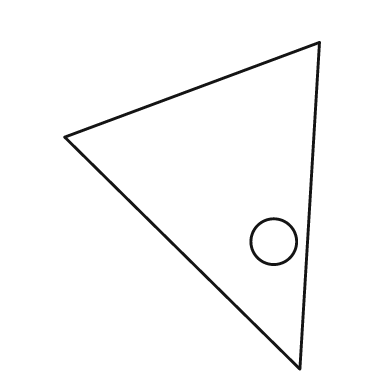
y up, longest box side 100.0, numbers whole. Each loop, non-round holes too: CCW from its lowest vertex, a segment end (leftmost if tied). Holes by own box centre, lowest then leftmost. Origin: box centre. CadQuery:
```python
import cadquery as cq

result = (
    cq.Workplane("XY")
    .moveTo(33.0, -50.0)
    .lineTo(39.0, 50.0)
    .lineTo(-39.0, 21.0)
    .close()
    .moveTo(25.0, -11.0)
    .circle(7.0)
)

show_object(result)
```